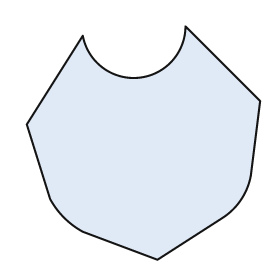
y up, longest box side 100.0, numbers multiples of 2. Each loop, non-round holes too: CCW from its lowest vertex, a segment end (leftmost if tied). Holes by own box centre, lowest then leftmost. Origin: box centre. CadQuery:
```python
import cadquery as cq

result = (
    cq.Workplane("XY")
    .moveTo(6.0, -50.0)
    .lineTo(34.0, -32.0)
    .threePointArc((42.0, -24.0), (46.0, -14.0))
    .lineTo(50.0, 18.0)
    .lineTo(18.0, 50.0)
    .threePointArc((-2.0, 28.0), (-26.0, 46.0))
    .lineTo(-50.0, 8.0)
    .lineTo(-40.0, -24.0)
    .threePointArc((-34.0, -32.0), (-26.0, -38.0))
    .close()
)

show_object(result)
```